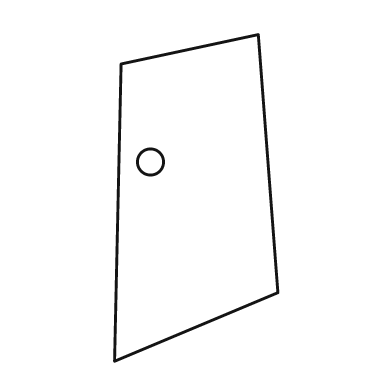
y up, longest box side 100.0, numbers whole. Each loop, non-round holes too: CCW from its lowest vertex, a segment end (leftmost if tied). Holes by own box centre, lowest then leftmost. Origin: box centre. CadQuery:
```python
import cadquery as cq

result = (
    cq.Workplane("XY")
    .moveTo(-25.0, -50.0)
    .lineTo(25.0, -29.0)
    .lineTo(19.0, 50.0)
    .lineTo(-23.0, 41.0)
    .close()
    .moveTo(-14.0, 11.0)
    .circle(4.0)
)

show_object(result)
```